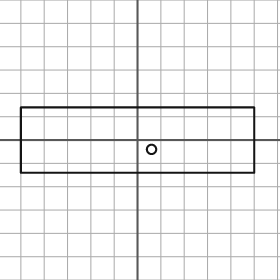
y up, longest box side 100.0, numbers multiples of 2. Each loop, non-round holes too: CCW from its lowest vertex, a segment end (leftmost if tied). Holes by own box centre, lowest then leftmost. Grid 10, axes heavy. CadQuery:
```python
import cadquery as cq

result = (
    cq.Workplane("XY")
    .moveTo(-50.0, -14.0)
    .lineTo(50.0, -14.0)
    .lineTo(50.0, 14.0)
    .lineTo(-50.0, 14.0)
    .close()
    .moveTo(6.0, -4.0)
    .circle(2.0)
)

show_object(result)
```